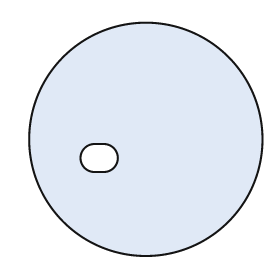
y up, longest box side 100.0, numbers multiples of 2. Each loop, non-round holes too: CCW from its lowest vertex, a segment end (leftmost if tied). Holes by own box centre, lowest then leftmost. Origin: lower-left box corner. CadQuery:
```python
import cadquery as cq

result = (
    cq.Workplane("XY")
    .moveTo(50.0, 50.0)
    .circle(50.0)
    .moveTo(28.0, 36.0)
    .lineTo(32.0, 36.0)
    .threePointArc((38.0, 42.0), (32.0, 48.0))
    .lineTo(28.0, 48.0)
    .threePointArc((22.0, 42.0), (28.0, 36.0))
    .close()
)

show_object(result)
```